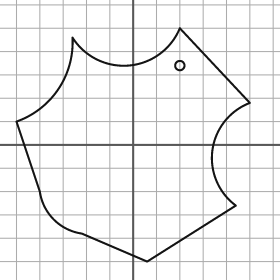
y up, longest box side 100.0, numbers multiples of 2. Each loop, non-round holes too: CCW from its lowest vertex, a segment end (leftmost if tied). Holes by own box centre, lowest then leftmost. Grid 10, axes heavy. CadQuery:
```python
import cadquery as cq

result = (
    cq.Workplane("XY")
    .moveTo(6.0, -50.0)
    .lineTo(44.0, -26.0)
    .threePointArc((34.0, -2.0), (50.0, 18.0))
    .lineTo(20.0, 50.0)
    .threePointArc((-2.0, 34.0), (-26.0, 46.0))
    .threePointArc((-32.0, 24.0), (-50.0, 10.0))
    .lineTo(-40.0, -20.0)
    .threePointArc((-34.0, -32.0), (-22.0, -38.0))
    .close()
    .moveTo(20.0, 34.0)
    .circle(2.0)
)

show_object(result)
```